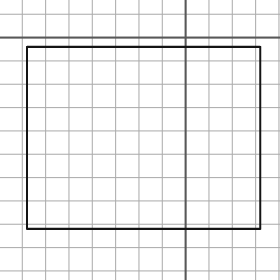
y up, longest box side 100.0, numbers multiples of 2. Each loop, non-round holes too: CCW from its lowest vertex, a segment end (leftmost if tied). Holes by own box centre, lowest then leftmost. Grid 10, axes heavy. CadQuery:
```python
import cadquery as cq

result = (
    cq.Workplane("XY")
    .moveTo(-68.0, -82.0)
    .lineTo(32.0, -82.0)
    .lineTo(32.0, -4.0)
    .lineTo(-68.0, -4.0)
    .close()
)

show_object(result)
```